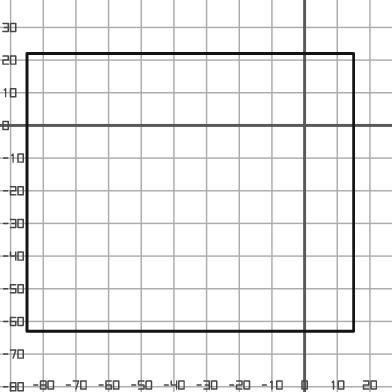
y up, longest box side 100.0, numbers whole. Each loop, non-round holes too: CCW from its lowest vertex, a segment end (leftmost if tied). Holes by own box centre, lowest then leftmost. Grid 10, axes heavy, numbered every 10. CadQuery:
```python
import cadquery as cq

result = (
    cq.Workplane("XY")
    .moveTo(-85.0, -63.0)
    .lineTo(15.0, -63.0)
    .lineTo(15.0, 22.0)
    .lineTo(-85.0, 22.0)
    .close()
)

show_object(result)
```